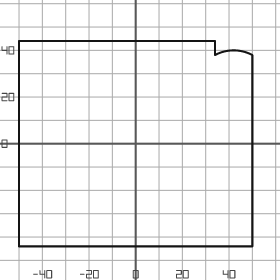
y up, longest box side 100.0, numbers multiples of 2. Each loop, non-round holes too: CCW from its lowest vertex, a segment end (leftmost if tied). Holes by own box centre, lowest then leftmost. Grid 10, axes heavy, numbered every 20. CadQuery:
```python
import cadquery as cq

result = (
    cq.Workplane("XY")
    .moveTo(-50.0, -44.0)
    .lineTo(50.0, -44.0)
    .lineTo(50.0, 38.0)
    .threePointArc((42.0, 40.0), (34.0, 38.0))
    .lineTo(34.0, 44.0)
    .lineTo(-50.0, 44.0)
    .close()
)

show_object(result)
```